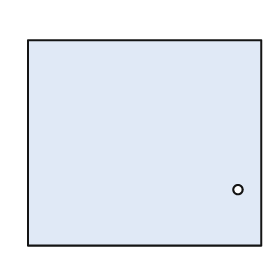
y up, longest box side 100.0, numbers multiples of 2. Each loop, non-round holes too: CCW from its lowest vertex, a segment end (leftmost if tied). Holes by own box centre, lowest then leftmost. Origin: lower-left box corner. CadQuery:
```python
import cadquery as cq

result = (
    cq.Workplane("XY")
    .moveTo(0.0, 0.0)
    .lineTo(100.0, 0.0)
    .lineTo(100.0, 88.0)
    .lineTo(0.0, 88.0)
    .close()
    .moveTo(90.0, 24.0)
    .circle(2.0)
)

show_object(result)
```